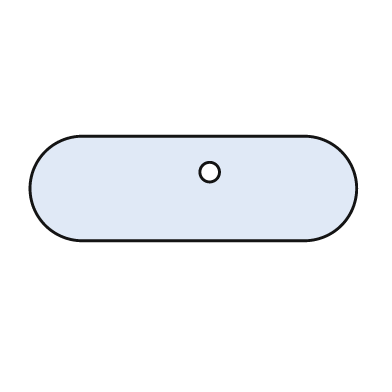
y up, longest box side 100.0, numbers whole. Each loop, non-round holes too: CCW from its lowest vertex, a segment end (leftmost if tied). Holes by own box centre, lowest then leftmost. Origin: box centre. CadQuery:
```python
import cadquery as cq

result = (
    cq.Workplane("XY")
    .moveTo(-34.0, -16.0)
    .lineTo(34.0, -16.0)
    .threePointArc((50.0, 0.0), (34.0, 16.0))
    .lineTo(-34.0, 16.0)
    .threePointArc((-50.0, 0.0), (-34.0, -16.0))
    .close()
    .moveTo(5.0, 5.0)
    .circle(3.0)
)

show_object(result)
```